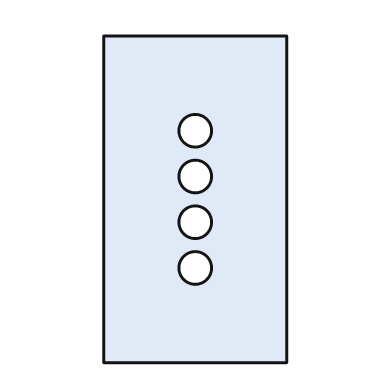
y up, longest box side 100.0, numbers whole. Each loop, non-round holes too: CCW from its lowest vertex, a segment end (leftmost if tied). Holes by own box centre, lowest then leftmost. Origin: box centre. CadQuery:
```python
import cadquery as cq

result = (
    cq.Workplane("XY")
    .moveTo(-28.0, -50.0)
    .lineTo(28.0, -50.0)
    .lineTo(28.0, 50.0)
    .lineTo(-28.0, 50.0)
    .close()
    .moveTo(0.0, -21.0)
    .circle(5.0)
    .moveTo(0.0, -7.0)
    .circle(5.0)
    .moveTo(0.0, 7.0)
    .circle(5.0)
    .moveTo(0.0, 21.0)
    .circle(5.0)
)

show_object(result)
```